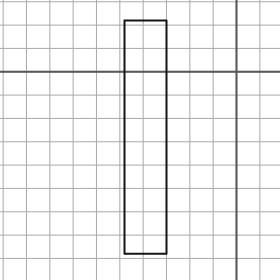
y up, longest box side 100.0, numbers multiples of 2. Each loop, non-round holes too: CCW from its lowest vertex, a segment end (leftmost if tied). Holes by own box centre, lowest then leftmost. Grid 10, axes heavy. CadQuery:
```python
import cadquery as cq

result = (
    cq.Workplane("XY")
    .moveTo(-48.0, -78.0)
    .lineTo(-30.0, -78.0)
    .lineTo(-30.0, 22.0)
    .lineTo(-48.0, 22.0)
    .close()
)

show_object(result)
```